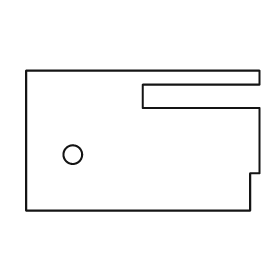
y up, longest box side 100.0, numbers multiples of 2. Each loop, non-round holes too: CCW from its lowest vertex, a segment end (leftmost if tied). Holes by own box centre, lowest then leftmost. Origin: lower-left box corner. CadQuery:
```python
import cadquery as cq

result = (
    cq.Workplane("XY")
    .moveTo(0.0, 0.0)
    .lineTo(96.0, 0.0)
    .lineTo(96.0, 16.0)
    .lineTo(100.0, 16.0)
    .lineTo(100.0, 44.0)
    .lineTo(50.0, 44.0)
    .lineTo(50.0, 54.0)
    .lineTo(100.0, 54.0)
    .lineTo(100.0, 60.0)
    .lineTo(0.0, 60.0)
    .close()
    .moveTo(20.0, 24.0)
    .circle(4.0)
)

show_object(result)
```